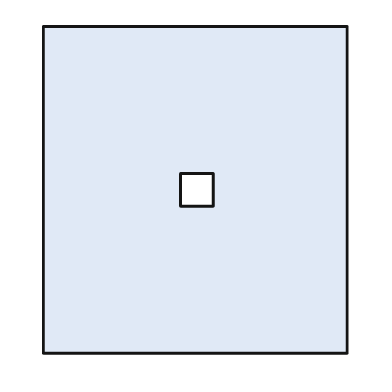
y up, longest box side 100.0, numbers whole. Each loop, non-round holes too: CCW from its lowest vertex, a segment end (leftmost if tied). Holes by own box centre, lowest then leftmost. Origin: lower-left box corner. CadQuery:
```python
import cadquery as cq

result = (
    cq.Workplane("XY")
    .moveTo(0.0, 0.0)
    .lineTo(93.0, 0.0)
    .lineTo(93.0, 100.0)
    .lineTo(0.0, 100.0)
    .close()
    .moveTo(42.0, 45.0)
    .lineTo(52.0, 45.0)
    .lineTo(52.0, 55.0)
    .lineTo(42.0, 55.0)
    .close()
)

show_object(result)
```